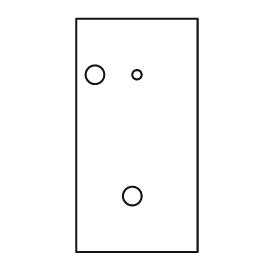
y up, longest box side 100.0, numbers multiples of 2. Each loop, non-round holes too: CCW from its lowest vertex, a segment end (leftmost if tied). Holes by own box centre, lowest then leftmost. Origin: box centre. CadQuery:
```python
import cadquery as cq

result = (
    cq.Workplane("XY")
    .moveTo(-26.0, -50.0)
    .lineTo(26.0, -50.0)
    .lineTo(26.0, 50.0)
    .lineTo(-26.0, 50.0)
    .close()
    .moveTo(-2.0, -26.0)
    .circle(4.0)
    .moveTo(-18.0, 26.0)
    .circle(4.0)
    .moveTo(0.0, 26.0)
    .circle(2.0)
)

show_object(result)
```